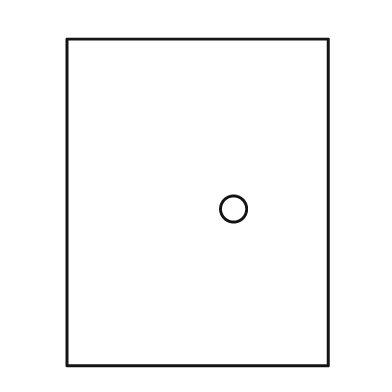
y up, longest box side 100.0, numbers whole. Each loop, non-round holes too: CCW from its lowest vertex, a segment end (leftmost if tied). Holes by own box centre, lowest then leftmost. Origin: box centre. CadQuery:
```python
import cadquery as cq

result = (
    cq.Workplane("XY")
    .moveTo(-40.0, -50.0)
    .lineTo(40.0, -50.0)
    .lineTo(40.0, 50.0)
    .lineTo(-40.0, 50.0)
    .close()
    .moveTo(11.0, -2.0)
    .circle(4.0)
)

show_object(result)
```